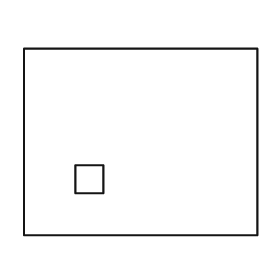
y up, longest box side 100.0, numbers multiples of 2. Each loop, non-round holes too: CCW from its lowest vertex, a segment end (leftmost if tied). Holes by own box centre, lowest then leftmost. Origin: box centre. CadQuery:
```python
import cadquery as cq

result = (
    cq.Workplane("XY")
    .moveTo(-50.0, -40.0)
    .lineTo(50.0, -40.0)
    .lineTo(50.0, 40.0)
    .lineTo(-50.0, 40.0)
    .close()
    .moveTo(-28.0, -22.0)
    .lineTo(-16.0, -22.0)
    .lineTo(-16.0, -10.0)
    .lineTo(-28.0, -10.0)
    .close()
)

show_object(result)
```